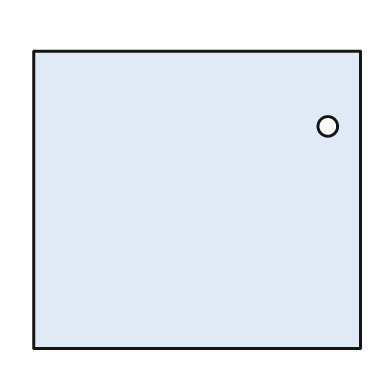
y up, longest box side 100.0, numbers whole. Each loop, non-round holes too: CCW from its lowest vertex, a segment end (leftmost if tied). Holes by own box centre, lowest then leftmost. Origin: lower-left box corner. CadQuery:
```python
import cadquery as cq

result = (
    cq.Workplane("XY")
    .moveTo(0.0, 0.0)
    .lineTo(100.0, 0.0)
    .lineTo(100.0, 91.0)
    .lineTo(0.0, 91.0)
    .close()
    .moveTo(90.0, 68.0)
    .circle(3.0)
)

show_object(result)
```